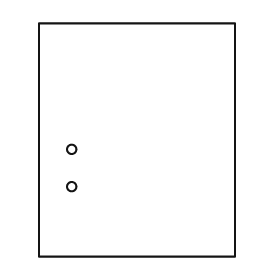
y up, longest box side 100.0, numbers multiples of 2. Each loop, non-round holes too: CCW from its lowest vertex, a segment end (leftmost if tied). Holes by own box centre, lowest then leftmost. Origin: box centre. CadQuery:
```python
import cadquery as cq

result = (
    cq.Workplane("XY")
    .moveTo(-42.0, -50.0)
    .lineTo(42.0, -50.0)
    .lineTo(42.0, 50.0)
    .lineTo(-42.0, 50.0)
    .close()
    .moveTo(-28.0, -20.0)
    .circle(2.0)
    .moveTo(-28.0, -4.0)
    .circle(2.0)
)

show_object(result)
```